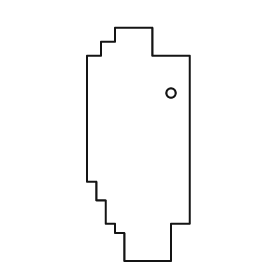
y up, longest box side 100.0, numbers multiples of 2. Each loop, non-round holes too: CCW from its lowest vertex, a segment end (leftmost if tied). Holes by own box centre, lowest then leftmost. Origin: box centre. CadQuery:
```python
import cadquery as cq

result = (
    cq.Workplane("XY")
    .moveTo(-6.0, -50.0)
    .lineTo(14.0, -50.0)
    .lineTo(14.0, -34.0)
    .lineTo(22.0, -34.0)
    .lineTo(22.0, 38.0)
    .lineTo(6.0, 38.0)
    .lineTo(6.0, 50.0)
    .lineTo(-10.0, 50.0)
    .lineTo(-10.0, 44.0)
    .lineTo(-16.0, 44.0)
    .lineTo(-16.0, 38.0)
    .lineTo(-22.0, 38.0)
    .lineTo(-22.0, -16.0)
    .lineTo(-18.0, -16.0)
    .lineTo(-18.0, -24.0)
    .lineTo(-14.0, -24.0)
    .lineTo(-14.0, -34.0)
    .lineTo(-10.0, -34.0)
    .lineTo(-10.0, -38.0)
    .lineTo(-6.0, -38.0)
    .close()
    .moveTo(14.0, 22.0)
    .circle(2.0)
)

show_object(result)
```